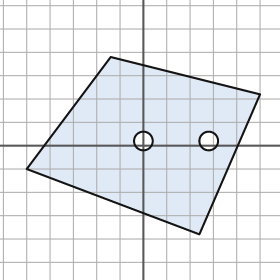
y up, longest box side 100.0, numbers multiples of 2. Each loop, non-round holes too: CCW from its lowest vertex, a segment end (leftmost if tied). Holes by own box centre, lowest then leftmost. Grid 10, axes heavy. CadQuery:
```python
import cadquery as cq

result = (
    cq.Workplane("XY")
    .moveTo(24.0, -38.0)
    .lineTo(50.0, 22.0)
    .lineTo(-14.0, 38.0)
    .lineTo(-50.0, -10.0)
    .close()
    .moveTo(0.0, 2.0)
    .circle(4.0)
    .moveTo(28.0, 2.0)
    .circle(4.0)
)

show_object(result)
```